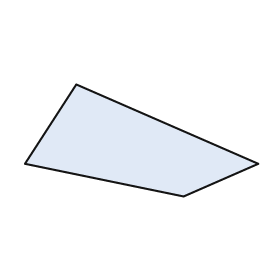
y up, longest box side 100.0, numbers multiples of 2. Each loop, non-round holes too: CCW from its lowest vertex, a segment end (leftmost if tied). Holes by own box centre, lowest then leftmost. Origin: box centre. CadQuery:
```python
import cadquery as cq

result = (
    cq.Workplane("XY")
    .moveTo(18.0, -24.0)
    .lineTo(50.0, -10.0)
    .lineTo(-28.0, 24.0)
    .lineTo(-50.0, -10.0)
    .close()
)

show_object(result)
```